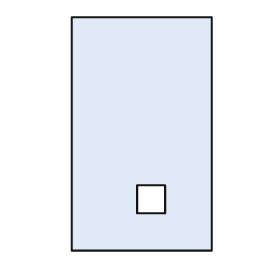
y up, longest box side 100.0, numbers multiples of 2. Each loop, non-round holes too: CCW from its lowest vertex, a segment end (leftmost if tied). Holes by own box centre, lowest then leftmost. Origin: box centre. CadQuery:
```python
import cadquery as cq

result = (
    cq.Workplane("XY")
    .moveTo(-30.0, -50.0)
    .lineTo(30.0, -50.0)
    .lineTo(30.0, 50.0)
    .lineTo(-30.0, 50.0)
    .close()
    .moveTo(-2.0, -34.0)
    .lineTo(10.0, -34.0)
    .lineTo(10.0, -22.0)
    .lineTo(-2.0, -22.0)
    .close()
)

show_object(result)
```